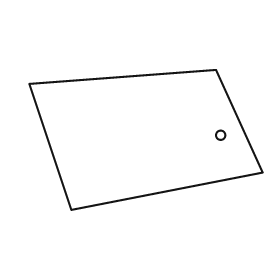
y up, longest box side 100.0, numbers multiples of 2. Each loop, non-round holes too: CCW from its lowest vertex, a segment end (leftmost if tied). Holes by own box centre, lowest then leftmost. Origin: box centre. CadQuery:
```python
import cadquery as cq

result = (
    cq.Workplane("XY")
    .moveTo(-32.0, -30.0)
    .lineTo(50.0, -14.0)
    .lineTo(30.0, 30.0)
    .lineTo(-50.0, 24.0)
    .close()
    .moveTo(32.0, 2.0)
    .circle(2.0)
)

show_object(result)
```